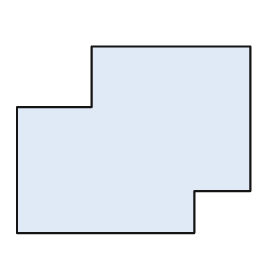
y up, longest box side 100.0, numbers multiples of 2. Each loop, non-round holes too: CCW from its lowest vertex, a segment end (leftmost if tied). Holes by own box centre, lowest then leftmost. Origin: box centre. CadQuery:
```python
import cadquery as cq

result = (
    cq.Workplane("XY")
    .moveTo(-50.0, -40.0)
    .lineTo(26.0, -40.0)
    .lineTo(26.0, -22.0)
    .lineTo(50.0, -22.0)
    .lineTo(50.0, 40.0)
    .lineTo(-18.0, 40.0)
    .lineTo(-18.0, 14.0)
    .lineTo(-50.0, 14.0)
    .close()
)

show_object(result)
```